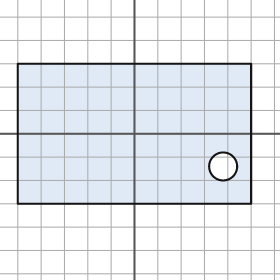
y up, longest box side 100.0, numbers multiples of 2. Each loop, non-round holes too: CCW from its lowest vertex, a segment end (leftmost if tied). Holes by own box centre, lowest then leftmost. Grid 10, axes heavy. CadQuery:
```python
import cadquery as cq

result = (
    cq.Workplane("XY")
    .moveTo(-50.0, -30.0)
    .lineTo(50.0, -30.0)
    .lineTo(50.0, 30.0)
    .lineTo(-50.0, 30.0)
    .close()
    .moveTo(38.0, -14.0)
    .circle(6.0)
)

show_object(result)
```